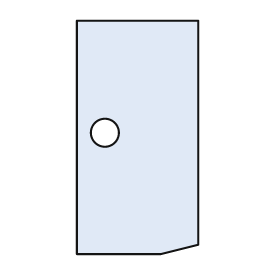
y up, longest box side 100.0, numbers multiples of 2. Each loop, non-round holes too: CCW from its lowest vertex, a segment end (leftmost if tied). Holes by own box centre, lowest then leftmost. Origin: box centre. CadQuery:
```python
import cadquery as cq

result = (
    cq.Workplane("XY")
    .moveTo(-26.0, -50.0)
    .lineTo(10.0, -50.0)
    .lineTo(26.0, -46.0)
    .lineTo(26.0, 50.0)
    .lineTo(-26.0, 50.0)
    .close()
    .moveTo(-14.0, 2.0)
    .circle(6.0)
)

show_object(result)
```